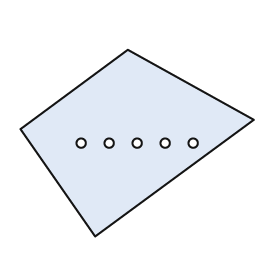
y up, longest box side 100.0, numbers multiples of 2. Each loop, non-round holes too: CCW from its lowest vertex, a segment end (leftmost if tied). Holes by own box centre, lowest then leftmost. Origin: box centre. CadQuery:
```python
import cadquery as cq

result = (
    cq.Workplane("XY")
    .moveTo(-18.0, -40.0)
    .lineTo(50.0, 10.0)
    .lineTo(-4.0, 40.0)
    .lineTo(-50.0, 6.0)
    .close()
    .moveTo(-24.0, 0.0)
    .circle(2.0)
    .moveTo(-12.0, 0.0)
    .circle(2.0)
    .moveTo(0.0, 0.0)
    .circle(2.0)
    .moveTo(12.0, 0.0)
    .circle(2.0)
    .moveTo(24.0, 0.0)
    .circle(2.0)
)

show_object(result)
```